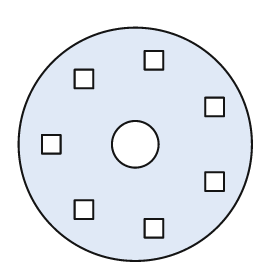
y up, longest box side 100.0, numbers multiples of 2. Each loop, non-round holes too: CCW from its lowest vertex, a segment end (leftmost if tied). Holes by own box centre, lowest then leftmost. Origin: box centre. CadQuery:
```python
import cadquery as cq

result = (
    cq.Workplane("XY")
    .moveTo(0.0, 0.0)
    .circle(50.0)
    .moveTo(4.0, -40.0)
    .lineTo(12.0, -40.0)
    .lineTo(12.0, -32.0)
    .lineTo(4.0, -32.0)
    .close()
    .moveTo(-26.0, -32.0)
    .lineTo(-18.0, -32.0)
    .lineTo(-18.0, -24.0)
    .lineTo(-26.0, -24.0)
    .close()
    .moveTo(30.0, -20.0)
    .lineTo(38.0, -20.0)
    .lineTo(38.0, -12.0)
    .lineTo(30.0, -12.0)
    .close()
    .moveTo(-40.0, -4.0)
    .lineTo(-32.0, -4.0)
    .lineTo(-32.0, 4.0)
    .lineTo(-40.0, 4.0)
    .close()
    .moveTo(0.0, 0.0)
    .circle(10.0)
    .moveTo(30.0, 12.0)
    .lineTo(38.0, 12.0)
    .lineTo(38.0, 20.0)
    .lineTo(30.0, 20.0)
    .close()
    .moveTo(-26.0, 24.0)
    .lineTo(-18.0, 24.0)
    .lineTo(-18.0, 32.0)
    .lineTo(-26.0, 32.0)
    .close()
    .moveTo(4.0, 32.0)
    .lineTo(12.0, 32.0)
    .lineTo(12.0, 40.0)
    .lineTo(4.0, 40.0)
    .close()
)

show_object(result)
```